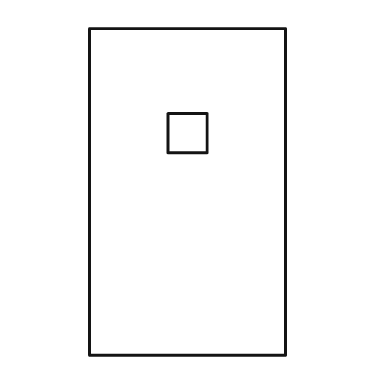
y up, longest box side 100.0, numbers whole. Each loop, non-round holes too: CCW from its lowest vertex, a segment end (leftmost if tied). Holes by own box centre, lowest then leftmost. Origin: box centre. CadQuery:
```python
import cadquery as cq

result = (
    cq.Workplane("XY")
    .moveTo(-30.0, -50.0)
    .lineTo(30.0, -50.0)
    .lineTo(30.0, 50.0)
    .lineTo(-30.0, 50.0)
    .close()
    .moveTo(-6.0, 12.0)
    .lineTo(6.0, 12.0)
    .lineTo(6.0, 24.0)
    .lineTo(-6.0, 24.0)
    .close()
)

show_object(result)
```